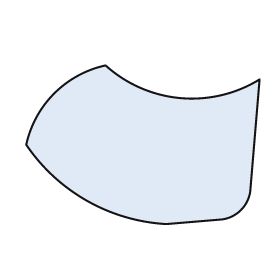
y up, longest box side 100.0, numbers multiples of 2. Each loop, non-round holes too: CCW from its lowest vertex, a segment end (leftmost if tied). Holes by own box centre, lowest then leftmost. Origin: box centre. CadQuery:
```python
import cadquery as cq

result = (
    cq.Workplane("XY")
    .moveTo(10.0, -34.0)
    .lineTo(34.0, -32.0)
    .threePointArc((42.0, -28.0), (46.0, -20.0))
    .lineTo(50.0, 28.0)
    .threePointArc((16.0, 20.0), (-16.0, 34.0))
    .threePointArc((-38.0, 22.0), (-50.0, 0.0))
    .threePointArc((-24.0, -24.0), (10.0, -34.0))
    .close()
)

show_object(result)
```